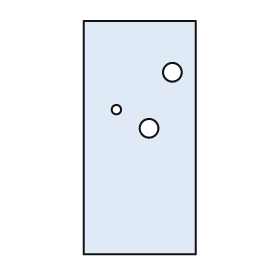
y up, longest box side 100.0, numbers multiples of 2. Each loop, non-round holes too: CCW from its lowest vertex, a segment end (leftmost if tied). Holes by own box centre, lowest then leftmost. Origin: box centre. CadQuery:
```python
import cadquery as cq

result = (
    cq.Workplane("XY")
    .moveTo(-24.0, -50.0)
    .lineTo(24.0, -50.0)
    .lineTo(24.0, 50.0)
    .lineTo(-24.0, 50.0)
    .close()
    .moveTo(4.0, 4.0)
    .circle(4.0)
    .moveTo(-10.0, 12.0)
    .circle(2.0)
    .moveTo(14.0, 28.0)
    .circle(4.0)
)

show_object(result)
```